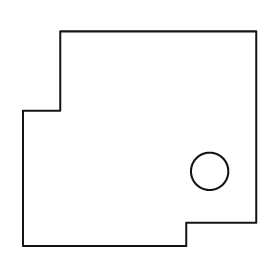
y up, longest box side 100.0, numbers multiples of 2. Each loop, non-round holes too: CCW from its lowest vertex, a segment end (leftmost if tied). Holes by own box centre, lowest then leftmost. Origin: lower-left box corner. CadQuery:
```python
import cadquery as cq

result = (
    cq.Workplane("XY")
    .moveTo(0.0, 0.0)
    .lineTo(70.0, 0.0)
    .lineTo(70.0, 10.0)
    .lineTo(100.0, 10.0)
    .lineTo(100.0, 92.0)
    .lineTo(16.0, 92.0)
    .lineTo(16.0, 58.0)
    .lineTo(0.0, 58.0)
    .close()
    .moveTo(80.0, 32.0)
    .circle(8.0)
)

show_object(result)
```